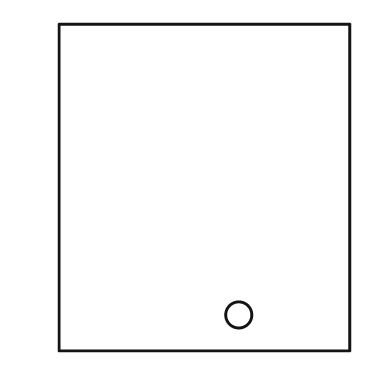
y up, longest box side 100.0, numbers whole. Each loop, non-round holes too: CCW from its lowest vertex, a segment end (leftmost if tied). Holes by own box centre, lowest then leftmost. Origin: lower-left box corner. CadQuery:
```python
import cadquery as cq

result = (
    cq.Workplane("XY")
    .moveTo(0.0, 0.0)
    .lineTo(89.0, 0.0)
    .lineTo(89.0, 100.0)
    .lineTo(0.0, 100.0)
    .close()
    .moveTo(55.0, 11.0)
    .circle(4.0)
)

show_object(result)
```